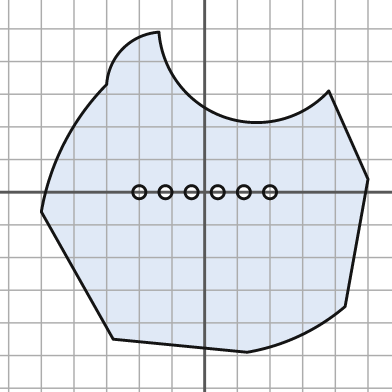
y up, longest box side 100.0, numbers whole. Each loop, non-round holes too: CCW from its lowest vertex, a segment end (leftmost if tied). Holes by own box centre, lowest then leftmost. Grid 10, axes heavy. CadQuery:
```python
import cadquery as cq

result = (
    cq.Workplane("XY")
    .moveTo(13.0, -49.0)
    .threePointArc((29.0, -44.0), (43.0, -35.0))
    .lineTo(50.0, 4.0)
    .lineTo(38.0, 31.0)
    .threePointArc((6.0, 23.0), (-14.0, 49.0))
    .threePointArc((-25.0, 44.0), (-30.0, 33.0))
    .threePointArc((-43.0, 15.0), (-50.0, -6.0))
    .lineTo(-28.0, -45.0)
    .close()
    .moveTo(-20.0, 0.0)
    .circle(2.0)
    .moveTo(-12.0, 0.0)
    .circle(2.0)
    .moveTo(-4.0, 0.0)
    .circle(2.0)
    .moveTo(4.0, 0.0)
    .circle(2.0)
    .moveTo(12.0, 0.0)
    .circle(2.0)
    .moveTo(20.0, 0.0)
    .circle(2.0)
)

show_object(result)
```